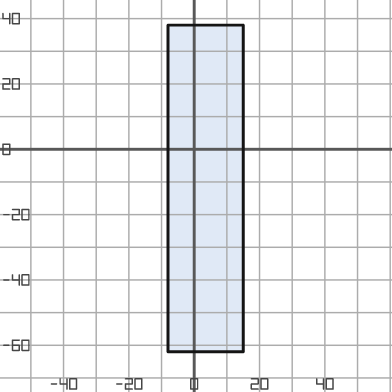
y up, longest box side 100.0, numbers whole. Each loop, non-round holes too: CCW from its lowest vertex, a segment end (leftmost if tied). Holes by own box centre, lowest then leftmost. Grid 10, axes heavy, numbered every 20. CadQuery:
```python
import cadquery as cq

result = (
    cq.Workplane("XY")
    .moveTo(-8.0, -62.0)
    .lineTo(15.0, -62.0)
    .lineTo(15.0, 38.0)
    .lineTo(-8.0, 38.0)
    .close()
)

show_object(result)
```